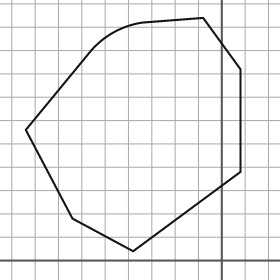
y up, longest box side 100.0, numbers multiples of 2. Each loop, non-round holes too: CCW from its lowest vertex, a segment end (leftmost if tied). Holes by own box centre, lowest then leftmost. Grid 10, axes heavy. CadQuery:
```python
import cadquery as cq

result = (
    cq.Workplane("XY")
    .moveTo(-38.0, 4.0)
    .lineTo(8.0, 38.0)
    .lineTo(8.0, 82.0)
    .lineTo(-8.0, 104.0)
    .lineTo(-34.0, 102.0)
    .threePointArc((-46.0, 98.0), (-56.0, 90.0))
    .lineTo(-84.0, 56.0)
    .lineTo(-64.0, 18.0)
    .close()
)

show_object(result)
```